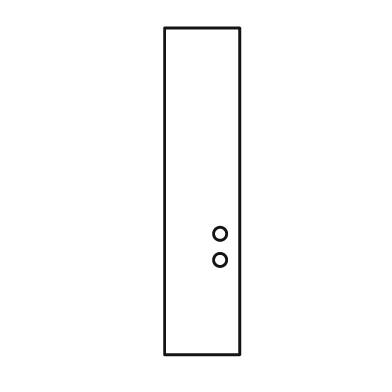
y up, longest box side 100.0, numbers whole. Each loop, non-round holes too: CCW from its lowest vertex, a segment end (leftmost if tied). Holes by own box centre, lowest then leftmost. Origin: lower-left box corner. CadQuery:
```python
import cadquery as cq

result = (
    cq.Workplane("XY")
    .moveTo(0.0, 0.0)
    .lineTo(23.0, 0.0)
    .lineTo(23.0, 100.0)
    .lineTo(0.0, 100.0)
    .close()
    .moveTo(17.0, 29.0)
    .circle(2.0)
    .moveTo(17.0, 37.0)
    .circle(2.0)
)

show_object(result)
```